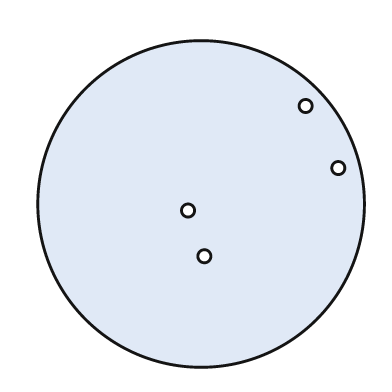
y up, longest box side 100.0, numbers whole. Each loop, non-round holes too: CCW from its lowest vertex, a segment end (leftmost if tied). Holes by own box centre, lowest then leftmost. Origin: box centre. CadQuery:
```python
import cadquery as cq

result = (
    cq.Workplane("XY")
    .moveTo(0.0, 0.0)
    .circle(50.0)
    .moveTo(1.0, -16.0)
    .circle(2.0)
    .moveTo(-4.0, -2.0)
    .circle(2.0)
    .moveTo(42.0, 11.0)
    .circle(2.0)
    .moveTo(32.0, 30.0)
    .circle(2.0)
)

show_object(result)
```